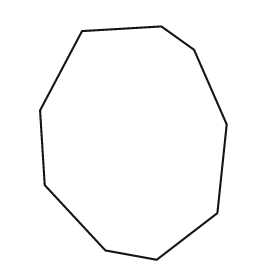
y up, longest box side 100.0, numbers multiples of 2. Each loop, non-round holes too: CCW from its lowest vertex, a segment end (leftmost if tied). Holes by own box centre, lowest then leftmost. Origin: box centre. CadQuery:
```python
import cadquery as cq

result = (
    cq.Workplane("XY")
    .moveTo(10.0, -50.0)
    .lineTo(36.0, -30.0)
    .lineTo(40.0, 8.0)
    .lineTo(26.0, 40.0)
    .lineTo(12.0, 50.0)
    .lineTo(-22.0, 48.0)
    .lineTo(-40.0, 14.0)
    .lineTo(-38.0, -18.0)
    .lineTo(-12.0, -46.0)
    .close()
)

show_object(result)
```